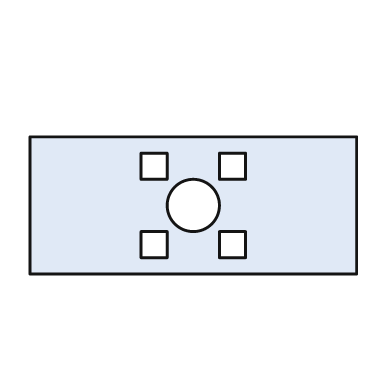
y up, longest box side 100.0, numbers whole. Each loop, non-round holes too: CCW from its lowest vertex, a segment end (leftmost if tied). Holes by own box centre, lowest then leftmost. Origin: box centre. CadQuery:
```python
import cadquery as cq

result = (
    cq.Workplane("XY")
    .moveTo(-50.0, -21.0)
    .lineTo(50.0, -21.0)
    .lineTo(50.0, 21.0)
    .lineTo(-50.0, 21.0)
    .close()
    .moveTo(-16.0, -16.0)
    .lineTo(-8.0, -16.0)
    .lineTo(-8.0, -8.0)
    .lineTo(-16.0, -8.0)
    .close()
    .moveTo(8.0, -16.0)
    .lineTo(16.0, -16.0)
    .lineTo(16.0, -8.0)
    .lineTo(8.0, -8.0)
    .close()
    .moveTo(0.0, 0.0)
    .circle(8.0)
    .moveTo(-16.0, 8.0)
    .lineTo(-8.0, 8.0)
    .lineTo(-8.0, 16.0)
    .lineTo(-16.0, 16.0)
    .close()
    .moveTo(8.0, 8.0)
    .lineTo(16.0, 8.0)
    .lineTo(16.0, 16.0)
    .lineTo(8.0, 16.0)
    .close()
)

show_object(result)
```